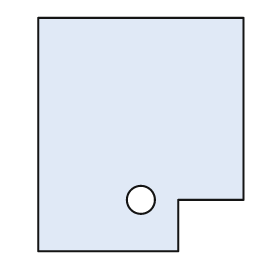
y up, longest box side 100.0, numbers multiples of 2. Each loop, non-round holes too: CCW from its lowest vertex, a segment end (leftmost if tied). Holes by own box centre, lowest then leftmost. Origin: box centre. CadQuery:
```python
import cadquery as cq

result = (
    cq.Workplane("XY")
    .moveTo(-44.0, -50.0)
    .lineTo(16.0, -50.0)
    .lineTo(16.0, -28.0)
    .lineTo(44.0, -28.0)
    .lineTo(44.0, 50.0)
    .lineTo(-44.0, 50.0)
    .close()
    .moveTo(0.0, -28.0)
    .circle(6.0)
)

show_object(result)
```